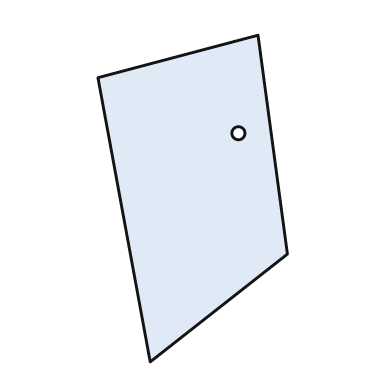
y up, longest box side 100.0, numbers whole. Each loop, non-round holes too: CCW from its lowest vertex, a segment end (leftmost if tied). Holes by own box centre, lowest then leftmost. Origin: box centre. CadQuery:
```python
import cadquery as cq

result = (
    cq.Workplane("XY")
    .moveTo(-13.0, -50.0)
    .lineTo(29.0, -17.0)
    .lineTo(20.0, 50.0)
    .lineTo(-29.0, 37.0)
    .close()
    .moveTo(14.0, 20.0)
    .circle(2.0)
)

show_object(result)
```